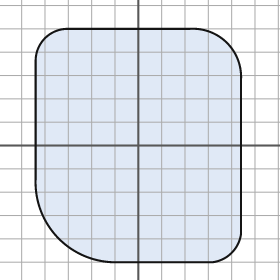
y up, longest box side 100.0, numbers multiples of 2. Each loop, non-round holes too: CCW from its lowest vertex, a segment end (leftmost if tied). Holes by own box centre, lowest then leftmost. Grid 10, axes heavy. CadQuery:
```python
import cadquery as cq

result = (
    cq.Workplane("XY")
    .moveTo(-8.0, -50.0)
    .lineTo(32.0, -50.0)
    .threePointArc((40.0, -46.0), (44.0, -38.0))
    .lineTo(44.0, 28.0)
    .threePointArc((38.0, 44.0), (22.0, 50.0))
    .lineTo(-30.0, 50.0)
    .threePointArc((-40.0, 46.0), (-44.0, 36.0))
    .lineTo(-44.0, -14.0)
    .threePointArc((-34.0, -40.0), (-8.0, -50.0))
    .close()
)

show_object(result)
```